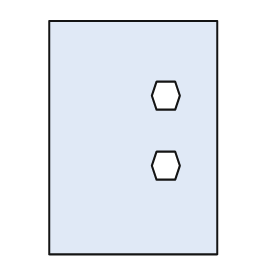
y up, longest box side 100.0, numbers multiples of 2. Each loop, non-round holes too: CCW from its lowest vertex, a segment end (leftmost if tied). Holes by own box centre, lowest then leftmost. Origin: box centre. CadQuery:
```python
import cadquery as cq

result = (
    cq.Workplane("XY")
    .moveTo(-36.0, -50.0)
    .lineTo(36.0, -50.0)
    .lineTo(36.0, 50.0)
    .lineTo(-36.0, 50.0)
    .close()
    .moveTo(10.0, -18.0)
    .lineTo(18.0, -18.0)
    .lineTo(20.0, -12.0)
    .lineTo(18.0, -6.0)
    .lineTo(10.0, -6.0)
    .lineTo(8.0, -12.0)
    .close()
    .moveTo(10.0, 12.0)
    .lineTo(18.0, 12.0)
    .lineTo(20.0, 18.0)
    .lineTo(18.0, 24.0)
    .lineTo(10.0, 24.0)
    .lineTo(8.0, 18.0)
    .close()
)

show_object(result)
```